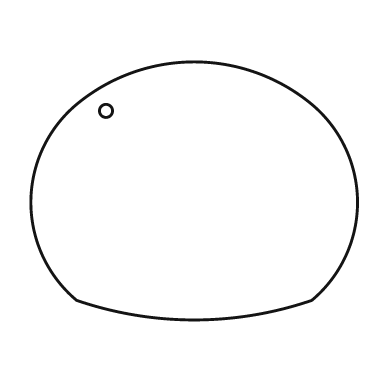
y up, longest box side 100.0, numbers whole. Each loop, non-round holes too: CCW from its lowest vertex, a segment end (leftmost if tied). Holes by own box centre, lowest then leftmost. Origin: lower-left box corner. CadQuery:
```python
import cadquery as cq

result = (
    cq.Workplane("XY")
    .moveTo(14.0, 6.0)
    .threePointArc((50.0, 0.0), (86.0, 6.0))
    .threePointArc((100.0, 36.0), (86.0, 66.0))
    .threePointArc((50.0, 79.0), (14.0, 66.0))
    .threePointArc((0.0, 36.0), (14.0, 6.0))
    .close()
    .moveTo(23.0, 64.0)
    .circle(2.0)
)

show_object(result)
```